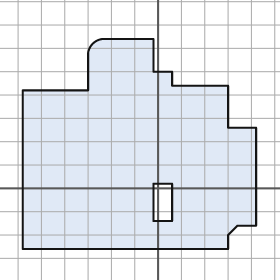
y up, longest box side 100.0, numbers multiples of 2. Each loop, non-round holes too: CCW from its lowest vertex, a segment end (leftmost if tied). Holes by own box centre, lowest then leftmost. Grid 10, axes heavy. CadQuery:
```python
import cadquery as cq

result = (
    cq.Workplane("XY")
    .moveTo(-58.0, -26.0)
    .lineTo(30.0, -26.0)
    .lineTo(30.0, -20.0)
    .lineTo(34.0, -16.0)
    .lineTo(42.0, -16.0)
    .lineTo(42.0, 26.0)
    .lineTo(30.0, 26.0)
    .lineTo(30.0, 44.0)
    .lineTo(6.0, 44.0)
    .lineTo(6.0, 50.0)
    .lineTo(-2.0, 50.0)
    .lineTo(-2.0, 64.0)
    .lineTo(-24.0, 64.0)
    .threePointArc((-28.0, 62.0), (-30.0, 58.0))
    .lineTo(-30.0, 42.0)
    .lineTo(-58.0, 42.0)
    .close()
    .moveTo(-2.0, -14.0)
    .lineTo(6.0, -14.0)
    .lineTo(6.0, 2.0)
    .lineTo(-2.0, 2.0)
    .close()
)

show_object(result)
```